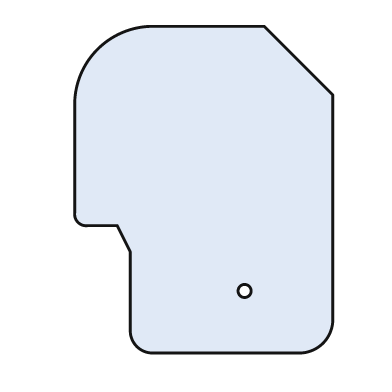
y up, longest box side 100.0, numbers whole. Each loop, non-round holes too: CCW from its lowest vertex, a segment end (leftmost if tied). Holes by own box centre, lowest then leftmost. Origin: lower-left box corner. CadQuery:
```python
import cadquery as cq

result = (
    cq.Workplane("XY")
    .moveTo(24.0, 0.0)
    .lineTo(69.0, 0.0)
    .threePointArc((76.0, 3.0), (79.0, 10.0))
    .lineTo(79.0, 79.0)
    .lineTo(58.0, 100.0)
    .lineTo(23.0, 100.0)
    .threePointArc((7.0, 93.0), (0.0, 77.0))
    .lineTo(0.0, 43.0)
    .threePointArc((1.0, 40.0), (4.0, 39.0))
    .lineTo(13.0, 39.0)
    .lineTo(17.0, 31.0)
    .lineTo(17.0, 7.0)
    .threePointArc((19.0, 2.0), (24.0, 0.0))
    .close()
    .moveTo(52.0, 19.0)
    .circle(2.0)
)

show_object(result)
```